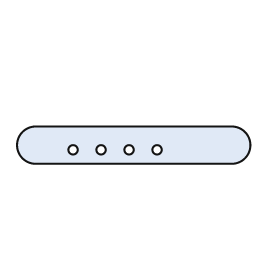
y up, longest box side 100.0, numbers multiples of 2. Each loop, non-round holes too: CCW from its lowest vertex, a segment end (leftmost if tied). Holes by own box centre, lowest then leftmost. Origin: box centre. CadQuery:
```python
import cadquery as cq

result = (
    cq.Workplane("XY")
    .moveTo(-42.0, -8.0)
    .lineTo(42.0, -8.0)
    .threePointArc((50.0, 0.0), (42.0, 8.0))
    .lineTo(-42.0, 8.0)
    .threePointArc((-50.0, 0.0), (-42.0, -8.0))
    .close()
    .moveTo(-26.0, -2.0)
    .circle(2.0)
    .moveTo(-14.0, -2.0)
    .circle(2.0)
    .moveTo(-2.0, -2.0)
    .circle(2.0)
    .moveTo(10.0, -2.0)
    .circle(2.0)
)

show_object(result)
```